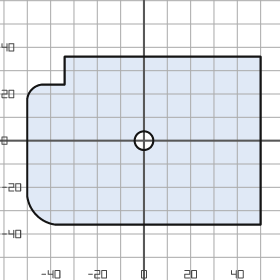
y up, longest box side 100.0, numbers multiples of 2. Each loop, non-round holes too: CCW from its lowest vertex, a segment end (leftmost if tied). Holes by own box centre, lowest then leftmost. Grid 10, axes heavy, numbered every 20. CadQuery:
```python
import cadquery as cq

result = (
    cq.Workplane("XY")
    .moveTo(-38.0, -36.0)
    .lineTo(50.0, -36.0)
    .lineTo(50.0, 36.0)
    .lineTo(-34.0, 36.0)
    .lineTo(-34.0, 24.0)
    .lineTo(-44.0, 24.0)
    .threePointArc((-48.0, 22.0), (-50.0, 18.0))
    .lineTo(-50.0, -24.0)
    .threePointArc((-46.0, -32.0), (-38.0, -36.0))
    .close()
    .moveTo(0.0, 0.0)
    .circle(4.0)
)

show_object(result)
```